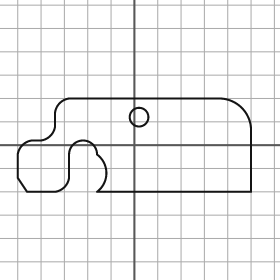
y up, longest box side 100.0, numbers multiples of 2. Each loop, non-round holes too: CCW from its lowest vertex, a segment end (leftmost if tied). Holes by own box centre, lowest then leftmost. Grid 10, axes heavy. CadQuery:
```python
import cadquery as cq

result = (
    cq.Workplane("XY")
    .moveTo(-46.0, -20.0)
    .lineTo(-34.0, -20.0)
    .threePointArc((-30.0, -18.0), (-28.0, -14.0))
    .lineTo(-28.0, -4.0)
    .threePointArc((-22.0, 2.0), (-16.0, -4.0))
    .threePointArc((-12.0, -12.0), (-16.0, -20.0))
    .lineTo(50.0, -20.0)
    .lineTo(50.0, 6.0)
    .threePointArc((46.0, 16.0), (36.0, 20.0))
    .lineTo(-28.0, 20.0)
    .threePointArc((-32.0, 18.0), (-34.0, 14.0))
    .lineTo(-34.0, 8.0)
    .threePointArc((-36.0, 4.0), (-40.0, 2.0))
    .lineTo(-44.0, 2.0)
    .threePointArc((-48.0, 0.0), (-50.0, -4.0))
    .lineTo(-50.0, -14.0)
    .close()
    .moveTo(2.0, 12.0)
    .circle(4.0)
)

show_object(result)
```